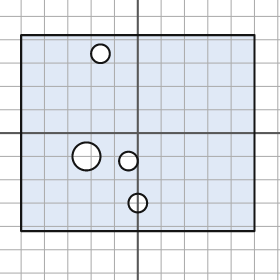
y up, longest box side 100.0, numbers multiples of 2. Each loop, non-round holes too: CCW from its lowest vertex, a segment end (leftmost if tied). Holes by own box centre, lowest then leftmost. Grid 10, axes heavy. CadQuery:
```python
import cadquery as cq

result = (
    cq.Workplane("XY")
    .moveTo(-50.0, -42.0)
    .lineTo(50.0, -42.0)
    .lineTo(50.0, 42.0)
    .lineTo(-50.0, 42.0)
    .close()
    .moveTo(0.0, -30.0)
    .circle(4.0)
    .moveTo(-4.0, -12.0)
    .circle(4.0)
    .moveTo(-22.0, -10.0)
    .circle(6.0)
    .moveTo(-16.0, 34.0)
    .circle(4.0)
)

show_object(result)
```